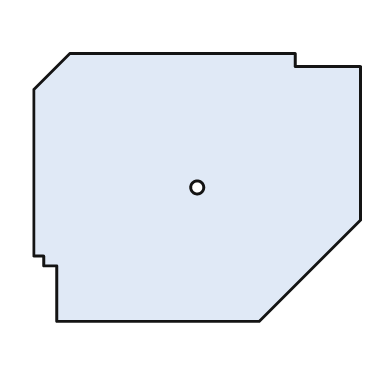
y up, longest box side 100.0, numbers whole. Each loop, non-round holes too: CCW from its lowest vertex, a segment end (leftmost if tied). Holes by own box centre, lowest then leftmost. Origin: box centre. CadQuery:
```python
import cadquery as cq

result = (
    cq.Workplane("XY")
    .moveTo(-43.0, -41.0)
    .lineTo(19.0, -41.0)
    .lineTo(50.0, -10.0)
    .lineTo(50.0, 37.0)
    .lineTo(30.0, 37.0)
    .lineTo(30.0, 41.0)
    .lineTo(-39.0, 41.0)
    .lineTo(-50.0, 30.0)
    .lineTo(-50.0, -21.0)
    .lineTo(-47.0, -21.0)
    .lineTo(-47.0, -24.0)
    .lineTo(-43.0, -24.0)
    .close()
    .moveTo(0.0, 0.0)
    .circle(2.0)
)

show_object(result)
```